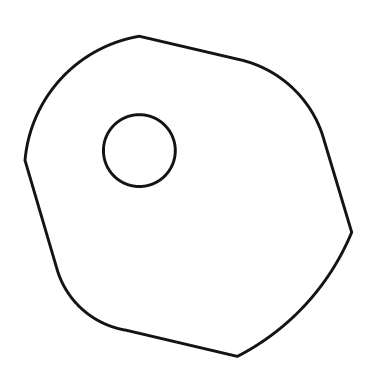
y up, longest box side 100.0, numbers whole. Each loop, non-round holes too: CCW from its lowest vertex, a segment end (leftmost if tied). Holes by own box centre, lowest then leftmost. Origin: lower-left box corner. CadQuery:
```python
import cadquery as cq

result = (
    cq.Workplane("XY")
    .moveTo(65.0, 0.0)
    .threePointArc((86.0, 16.0), (100.0, 38.0))
    .lineTo(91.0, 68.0)
    .threePointArc((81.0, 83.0), (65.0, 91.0))
    .lineTo(35.0, 98.0)
    .threePointArc((11.0, 85.0), (0.0, 60.0))
    .lineTo(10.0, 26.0)
    .threePointArc((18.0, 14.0), (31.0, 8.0))
    .close()
    .moveTo(35.0, 63.0)
    .circle(11.0)
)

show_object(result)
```